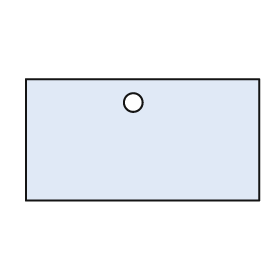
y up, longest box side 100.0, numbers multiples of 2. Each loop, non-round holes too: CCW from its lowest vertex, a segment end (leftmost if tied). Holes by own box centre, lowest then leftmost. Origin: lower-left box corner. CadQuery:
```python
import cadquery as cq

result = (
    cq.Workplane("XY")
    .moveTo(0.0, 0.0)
    .lineTo(100.0, 0.0)
    .lineTo(100.0, 52.0)
    .lineTo(0.0, 52.0)
    .close()
    .moveTo(46.0, 42.0)
    .circle(4.0)
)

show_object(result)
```